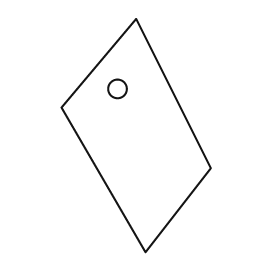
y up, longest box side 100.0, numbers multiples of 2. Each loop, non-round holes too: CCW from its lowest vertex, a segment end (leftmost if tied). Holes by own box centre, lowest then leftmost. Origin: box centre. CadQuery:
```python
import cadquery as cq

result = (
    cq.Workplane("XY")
    .moveTo(4.0, -50.0)
    .lineTo(32.0, -14.0)
    .lineTo(0.0, 50.0)
    .lineTo(-32.0, 12.0)
    .close()
    .moveTo(-8.0, 20.0)
    .circle(4.0)
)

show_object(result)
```